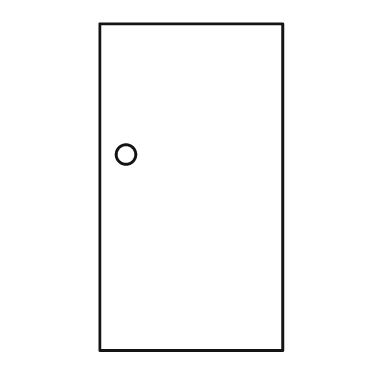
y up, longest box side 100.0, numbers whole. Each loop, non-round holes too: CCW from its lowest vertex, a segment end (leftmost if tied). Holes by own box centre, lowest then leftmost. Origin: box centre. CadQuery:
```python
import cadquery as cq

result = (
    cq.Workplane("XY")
    .moveTo(-28.0, -50.0)
    .lineTo(28.0, -50.0)
    .lineTo(28.0, 50.0)
    .lineTo(-28.0, 50.0)
    .close()
    .moveTo(-20.0, 10.0)
    .circle(3.0)
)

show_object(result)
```